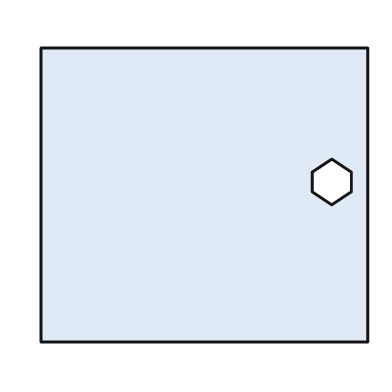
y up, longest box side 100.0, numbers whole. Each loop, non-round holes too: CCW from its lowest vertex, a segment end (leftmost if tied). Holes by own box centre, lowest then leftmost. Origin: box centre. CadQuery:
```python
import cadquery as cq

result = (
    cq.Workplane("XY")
    .moveTo(-50.0, -45.0)
    .lineTo(50.0, -45.0)
    .lineTo(50.0, 45.0)
    .lineTo(-50.0, 45.0)
    .close()
    .moveTo(39.0, -3.0)
    .lineTo(45.0, 1.0)
    .lineTo(45.0, 7.0)
    .lineTo(39.0, 11.0)
    .lineTo(33.0, 7.0)
    .lineTo(33.0, 1.0)
    .close()
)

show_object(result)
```